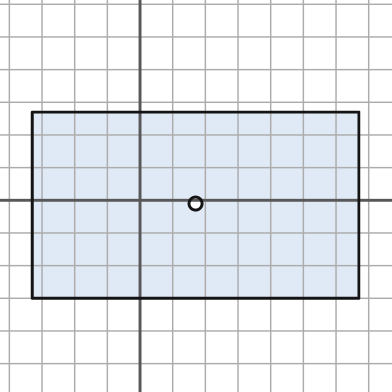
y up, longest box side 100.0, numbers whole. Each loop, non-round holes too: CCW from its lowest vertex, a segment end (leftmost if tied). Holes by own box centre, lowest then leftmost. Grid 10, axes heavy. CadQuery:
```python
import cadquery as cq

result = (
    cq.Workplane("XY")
    .moveTo(-33.0, -30.0)
    .lineTo(67.0, -30.0)
    .lineTo(67.0, 27.0)
    .lineTo(-33.0, 27.0)
    .close()
    .moveTo(17.0, -1.0)
    .circle(2.0)
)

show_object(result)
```